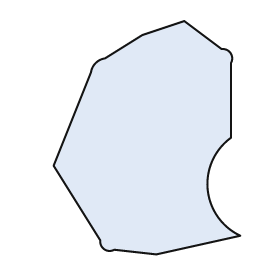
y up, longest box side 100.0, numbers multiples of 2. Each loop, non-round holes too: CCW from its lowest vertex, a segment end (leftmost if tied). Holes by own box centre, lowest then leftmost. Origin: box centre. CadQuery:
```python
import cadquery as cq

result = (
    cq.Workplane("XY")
    .moveTo(4.0, -50.0)
    .lineTo(40.0, -42.0)
    .threePointArc((26.0, -22.0), (36.0, 0.0))
    .lineTo(36.0, 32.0)
    .threePointArc((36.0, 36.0), (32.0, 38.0))
    .lineTo(16.0, 50.0)
    .lineTo(-2.0, 44.0)
    .lineTo(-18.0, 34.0)
    .threePointArc((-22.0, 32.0), (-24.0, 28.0))
    .lineTo(-40.0, -12.0)
    .lineTo(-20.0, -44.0)
    .threePointArc((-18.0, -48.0), (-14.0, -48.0))
    .close()
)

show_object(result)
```